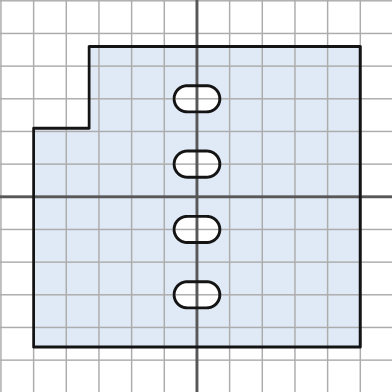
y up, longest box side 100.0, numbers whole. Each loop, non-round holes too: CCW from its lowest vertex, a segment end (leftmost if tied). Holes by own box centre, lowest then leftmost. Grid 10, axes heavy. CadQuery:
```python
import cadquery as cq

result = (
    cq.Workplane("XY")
    .moveTo(-50.0, -46.0)
    .lineTo(50.0, -46.0)
    .lineTo(50.0, 46.0)
    .lineTo(-33.0, 46.0)
    .lineTo(-33.0, 21.0)
    .lineTo(-50.0, 21.0)
    .close()
    .moveTo(-3.0, -34.0)
    .lineTo(3.0, -34.0)
    .threePointArc((7.0, -30.0), (3.0, -26.0))
    .lineTo(-3.0, -26.0)
    .threePointArc((-7.0, -30.0), (-3.0, -34.0))
    .close()
    .moveTo(-3.0, -14.0)
    .lineTo(3.0, -14.0)
    .threePointArc((7.0, -10.0), (3.0, -6.0))
    .lineTo(-3.0, -6.0)
    .threePointArc((-7.0, -10.0), (-3.0, -14.0))
    .close()
    .moveTo(-3.0, 6.0)
    .lineTo(3.0, 6.0)
    .threePointArc((7.0, 10.0), (3.0, 14.0))
    .lineTo(-3.0, 14.0)
    .threePointArc((-7.0, 10.0), (-3.0, 6.0))
    .close()
    .moveTo(-3.0, 26.0)
    .lineTo(3.0, 26.0)
    .threePointArc((7.0, 30.0), (3.0, 34.0))
    .lineTo(-3.0, 34.0)
    .threePointArc((-7.0, 30.0), (-3.0, 26.0))
    .close()
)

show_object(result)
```